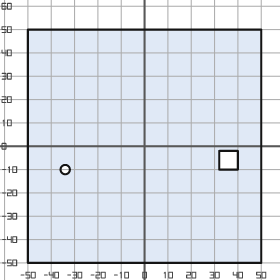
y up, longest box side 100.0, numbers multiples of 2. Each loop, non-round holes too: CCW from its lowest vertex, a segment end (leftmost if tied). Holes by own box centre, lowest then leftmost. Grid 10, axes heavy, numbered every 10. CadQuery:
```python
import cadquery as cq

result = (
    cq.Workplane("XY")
    .moveTo(-50.0, -50.0)
    .lineTo(50.0, -50.0)
    .lineTo(50.0, 50.0)
    .lineTo(-50.0, 50.0)
    .close()
    .moveTo(-34.0, -10.0)
    .circle(2.0)
    .moveTo(32.0, -10.0)
    .lineTo(40.0, -10.0)
    .lineTo(40.0, -2.0)
    .lineTo(32.0, -2.0)
    .close()
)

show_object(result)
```